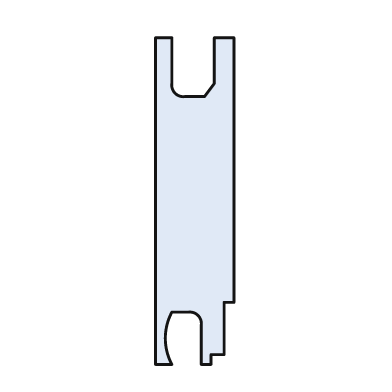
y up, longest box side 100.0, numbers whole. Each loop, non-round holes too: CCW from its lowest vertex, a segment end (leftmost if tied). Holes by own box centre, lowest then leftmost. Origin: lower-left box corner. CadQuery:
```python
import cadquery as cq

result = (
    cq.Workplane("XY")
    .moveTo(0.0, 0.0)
    .lineTo(5.0, 0.0)
    .threePointArc((3.0, 8.0), (5.0, 16.0))
    .lineTo(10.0, 16.0)
    .threePointArc((13.0, 15.0), (14.0, 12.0))
    .lineTo(14.0, 0.0)
    .lineTo(17.0, 0.0)
    .lineTo(17.0, 3.0)
    .lineTo(21.0, 3.0)
    .lineTo(21.0, 19.0)
    .lineTo(24.0, 19.0)
    .lineTo(24.0, 100.0)
    .lineTo(18.0, 100.0)
    .lineTo(18.0, 86.0)
    .lineTo(15.0, 82.0)
    .lineTo(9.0, 82.0)
    .threePointArc((6.0, 83.0), (5.0, 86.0))
    .lineTo(5.0, 100.0)
    .lineTo(0.0, 100.0)
    .close()
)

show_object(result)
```